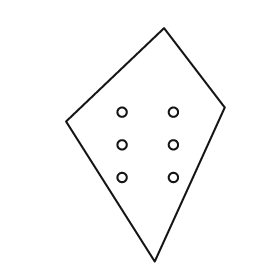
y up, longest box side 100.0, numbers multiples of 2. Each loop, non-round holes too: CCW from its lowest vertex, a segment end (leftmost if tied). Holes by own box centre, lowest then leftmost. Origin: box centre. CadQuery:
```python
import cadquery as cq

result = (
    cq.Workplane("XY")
    .moveTo(4.0, -50.0)
    .lineTo(34.0, 16.0)
    .lineTo(8.0, 50.0)
    .lineTo(-34.0, 10.0)
    .close()
    .moveTo(-10.0, -14.0)
    .circle(2.0)
    .moveTo(12.0, -14.0)
    .circle(2.0)
    .moveTo(-10.0, 0.0)
    .circle(2.0)
    .moveTo(12.0, 0.0)
    .circle(2.0)
    .moveTo(-10.0, 14.0)
    .circle(2.0)
    .moveTo(12.0, 14.0)
    .circle(2.0)
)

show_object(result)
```